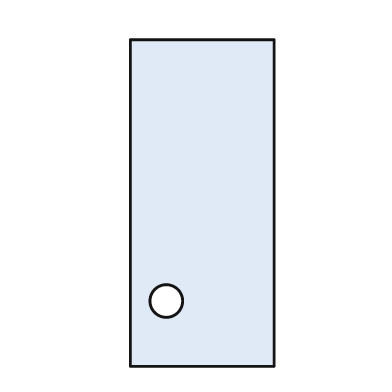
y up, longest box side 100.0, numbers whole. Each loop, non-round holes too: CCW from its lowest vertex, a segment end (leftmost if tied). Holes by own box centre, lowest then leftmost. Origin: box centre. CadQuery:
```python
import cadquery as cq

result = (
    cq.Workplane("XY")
    .moveTo(-22.0, -50.0)
    .lineTo(22.0, -50.0)
    .lineTo(22.0, 50.0)
    .lineTo(-22.0, 50.0)
    .close()
    .moveTo(-11.0, -30.0)
    .circle(5.0)
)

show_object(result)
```